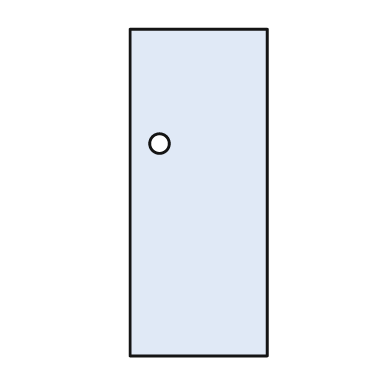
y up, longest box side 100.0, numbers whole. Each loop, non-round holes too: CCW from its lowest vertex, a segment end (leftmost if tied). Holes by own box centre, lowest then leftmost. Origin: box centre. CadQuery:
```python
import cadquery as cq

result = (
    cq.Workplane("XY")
    .moveTo(-21.0, -50.0)
    .lineTo(21.0, -50.0)
    .lineTo(21.0, 50.0)
    .lineTo(-21.0, 50.0)
    .close()
    .moveTo(-12.0, 15.0)
    .circle(3.0)
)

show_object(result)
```